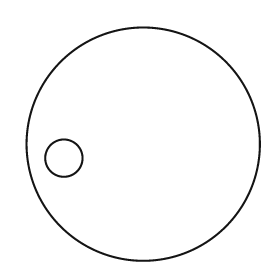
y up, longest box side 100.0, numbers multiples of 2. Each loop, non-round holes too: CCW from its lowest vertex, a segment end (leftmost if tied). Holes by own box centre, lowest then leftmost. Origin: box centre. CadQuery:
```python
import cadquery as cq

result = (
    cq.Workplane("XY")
    .moveTo(0.0, 0.0)
    .circle(50.0)
    .moveTo(-34.0, -6.0)
    .circle(8.0)
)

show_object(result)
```